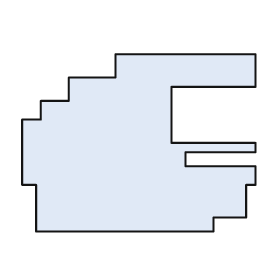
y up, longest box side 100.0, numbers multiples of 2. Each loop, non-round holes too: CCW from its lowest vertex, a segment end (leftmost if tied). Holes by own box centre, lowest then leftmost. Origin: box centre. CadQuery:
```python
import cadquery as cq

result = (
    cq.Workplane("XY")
    .moveTo(-44.0, -38.0)
    .lineTo(32.0, -38.0)
    .lineTo(32.0, -32.0)
    .lineTo(46.0, -32.0)
    .lineTo(46.0, -18.0)
    .lineTo(50.0, -18.0)
    .lineTo(50.0, -10.0)
    .lineTo(20.0, -10.0)
    .lineTo(20.0, -4.0)
    .lineTo(50.0, -4.0)
    .lineTo(50.0, 0.0)
    .lineTo(14.0, 0.0)
    .lineTo(14.0, 24.0)
    .lineTo(50.0, 24.0)
    .lineTo(50.0, 38.0)
    .lineTo(-10.0, 38.0)
    .lineTo(-10.0, 28.0)
    .lineTo(-30.0, 28.0)
    .lineTo(-30.0, 18.0)
    .lineTo(-42.0, 18.0)
    .lineTo(-42.0, 10.0)
    .lineTo(-50.0, 10.0)
    .lineTo(-50.0, -18.0)
    .lineTo(-44.0, -18.0)
    .close()
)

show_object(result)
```